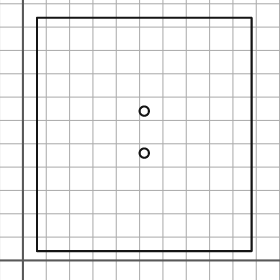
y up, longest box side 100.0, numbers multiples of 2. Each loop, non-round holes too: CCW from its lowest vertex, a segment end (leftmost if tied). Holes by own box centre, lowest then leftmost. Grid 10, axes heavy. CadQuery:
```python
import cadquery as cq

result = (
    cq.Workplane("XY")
    .moveTo(6.0, 4.0)
    .lineTo(98.0, 4.0)
    .lineTo(98.0, 104.0)
    .lineTo(6.0, 104.0)
    .close()
    .moveTo(52.0, 46.0)
    .circle(2.0)
    .moveTo(52.0, 64.0)
    .circle(2.0)
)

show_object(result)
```